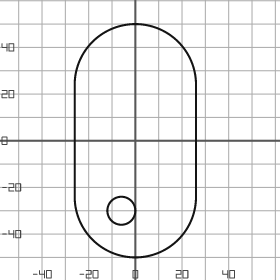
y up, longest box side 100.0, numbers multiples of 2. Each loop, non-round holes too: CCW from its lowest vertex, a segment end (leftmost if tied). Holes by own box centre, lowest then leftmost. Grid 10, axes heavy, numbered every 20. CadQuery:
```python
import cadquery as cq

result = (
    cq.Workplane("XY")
    .moveTo(-26.0, -24.0)
    .threePointArc((0.0, -50.0), (26.0, -24.0))
    .lineTo(26.0, 24.0)
    .threePointArc((0.0, 50.0), (-26.0, 24.0))
    .close()
    .moveTo(-6.0, -30.0)
    .circle(6.0)
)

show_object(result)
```